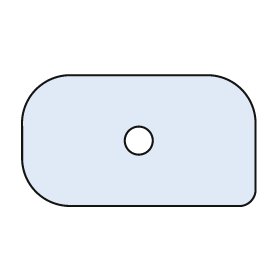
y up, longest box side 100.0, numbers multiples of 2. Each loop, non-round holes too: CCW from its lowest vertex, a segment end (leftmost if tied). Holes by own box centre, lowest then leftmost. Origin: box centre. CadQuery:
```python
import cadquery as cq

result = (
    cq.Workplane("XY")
    .moveTo(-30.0, -28.0)
    .lineTo(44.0, -28.0)
    .threePointArc((48.0, -26.0), (50.0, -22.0))
    .lineTo(50.0, 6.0)
    .threePointArc((44.0, 22.0), (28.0, 28.0))
    .lineTo(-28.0, 28.0)
    .threePointArc((-44.0, 22.0), (-50.0, 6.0))
    .lineTo(-50.0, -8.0)
    .threePointArc((-44.0, -22.0), (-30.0, -28.0))
    .close()
    .moveTo(0.0, 0.0)
    .circle(6.0)
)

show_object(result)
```